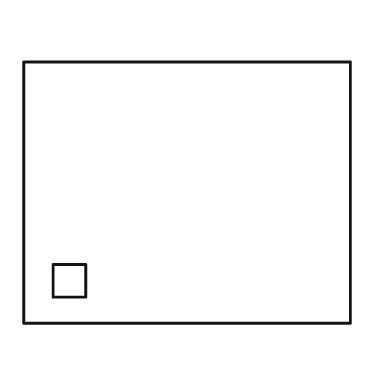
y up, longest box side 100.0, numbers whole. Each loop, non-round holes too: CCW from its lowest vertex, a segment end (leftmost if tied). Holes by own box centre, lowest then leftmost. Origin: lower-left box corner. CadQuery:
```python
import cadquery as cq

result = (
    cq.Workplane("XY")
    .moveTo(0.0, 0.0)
    .lineTo(100.0, 0.0)
    .lineTo(100.0, 80.0)
    .lineTo(0.0, 80.0)
    .close()
    .moveTo(9.0, 8.0)
    .lineTo(19.0, 8.0)
    .lineTo(19.0, 18.0)
    .lineTo(9.0, 18.0)
    .close()
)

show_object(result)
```